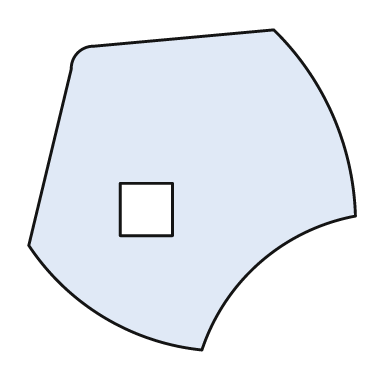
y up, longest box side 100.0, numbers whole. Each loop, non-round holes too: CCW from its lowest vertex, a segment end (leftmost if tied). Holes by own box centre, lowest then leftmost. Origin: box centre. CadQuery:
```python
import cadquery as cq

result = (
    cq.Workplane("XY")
    .moveTo(3.0, -49.0)
    .threePointArc((21.0, -22.0), (50.0, -8.0))
    .threePointArc((43.0, 23.0), (25.0, 49.0))
    .lineTo(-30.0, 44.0)
    .threePointArc((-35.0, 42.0), (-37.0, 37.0))
    .lineTo(-50.0, -17.0)
    .threePointArc((-27.0, -39.0), (3.0, -49.0))
    .close()
    .moveTo(-22.0, -14.0)
    .lineTo(-6.0, -14.0)
    .lineTo(-6.0, 2.0)
    .lineTo(-22.0, 2.0)
    .close()
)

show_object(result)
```